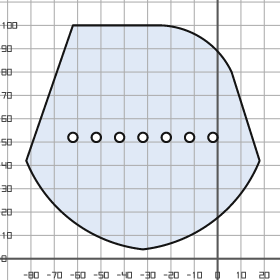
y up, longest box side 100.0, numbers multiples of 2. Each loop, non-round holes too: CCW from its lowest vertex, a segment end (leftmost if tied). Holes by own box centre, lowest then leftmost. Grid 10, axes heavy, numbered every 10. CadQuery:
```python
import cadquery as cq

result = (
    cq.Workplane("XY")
    .moveTo(-32.0, 4.0)
    .threePointArc((-2.0, 16.0), (18.0, 42.0))
    .lineTo(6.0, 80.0)
    .threePointArc((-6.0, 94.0), (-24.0, 100.0))
    .lineTo(-62.0, 100.0)
    .lineTo(-82.0, 42.0)
    .threePointArc((-62.0, 16.0), (-32.0, 4.0))
    .close()
    .moveTo(-62.0, 52.0)
    .circle(2.0)
    .moveTo(-52.0, 52.0)
    .circle(2.0)
    .moveTo(-42.0, 52.0)
    .circle(2.0)
    .moveTo(-32.0, 52.0)
    .circle(2.0)
    .moveTo(-22.0, 52.0)
    .circle(2.0)
    .moveTo(-12.0, 52.0)
    .circle(2.0)
    .moveTo(-2.0, 52.0)
    .circle(2.0)
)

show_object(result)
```